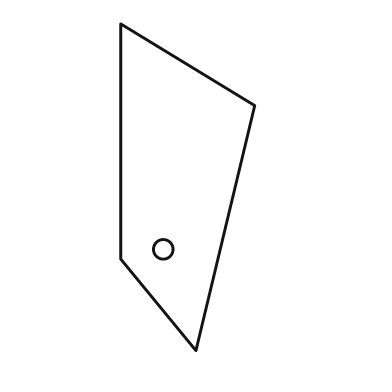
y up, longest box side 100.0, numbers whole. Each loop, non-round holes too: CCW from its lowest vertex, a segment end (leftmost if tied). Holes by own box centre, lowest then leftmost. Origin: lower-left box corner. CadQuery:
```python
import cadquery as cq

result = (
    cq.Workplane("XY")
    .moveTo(23.0, 0.0)
    .lineTo(41.0, 75.0)
    .lineTo(0.0, 100.0)
    .lineTo(0.0, 28.0)
    .close()
    .moveTo(13.0, 31.0)
    .circle(3.0)
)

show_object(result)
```